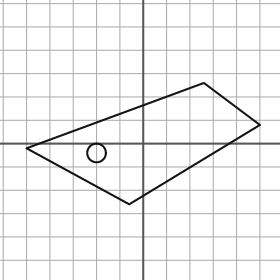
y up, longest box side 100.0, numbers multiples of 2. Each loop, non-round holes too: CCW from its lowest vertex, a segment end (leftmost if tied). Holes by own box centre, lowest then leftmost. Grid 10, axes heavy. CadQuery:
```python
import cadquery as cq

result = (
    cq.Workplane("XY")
    .moveTo(-6.0, -26.0)
    .lineTo(50.0, 8.0)
    .lineTo(26.0, 26.0)
    .lineTo(-50.0, -2.0)
    .close()
    .moveTo(-20.0, -4.0)
    .circle(4.0)
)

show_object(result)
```